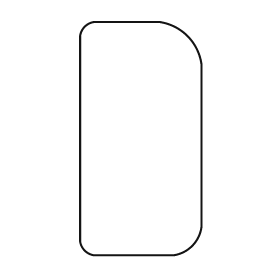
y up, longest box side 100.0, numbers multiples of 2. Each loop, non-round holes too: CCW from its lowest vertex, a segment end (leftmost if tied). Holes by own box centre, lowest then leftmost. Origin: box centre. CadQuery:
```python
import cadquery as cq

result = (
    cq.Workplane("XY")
    .moveTo(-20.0, -50.0)
    .lineTo(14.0, -50.0)
    .threePointArc((22.0, -46.0), (26.0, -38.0))
    .lineTo(26.0, 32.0)
    .threePointArc((20.0, 44.0), (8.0, 50.0))
    .lineTo(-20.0, 50.0)
    .threePointArc((-24.0, 48.0), (-26.0, 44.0))
    .lineTo(-26.0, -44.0)
    .threePointArc((-24.0, -48.0), (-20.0, -50.0))
    .close()
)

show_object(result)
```